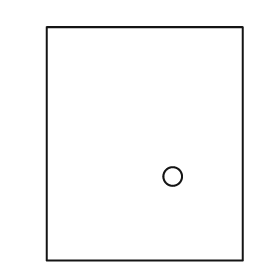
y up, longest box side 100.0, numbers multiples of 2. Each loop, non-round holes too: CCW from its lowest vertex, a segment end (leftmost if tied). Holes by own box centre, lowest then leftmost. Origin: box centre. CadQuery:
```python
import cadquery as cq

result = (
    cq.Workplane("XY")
    .moveTo(-42.0, -50.0)
    .lineTo(42.0, -50.0)
    .lineTo(42.0, 50.0)
    .lineTo(-42.0, 50.0)
    .close()
    .moveTo(12.0, -14.0)
    .circle(4.0)
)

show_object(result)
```